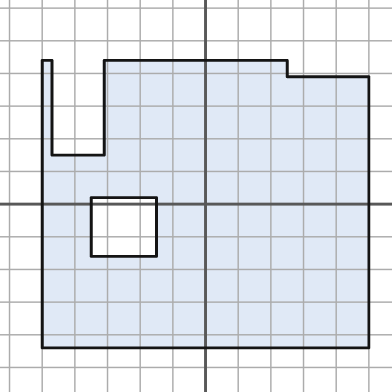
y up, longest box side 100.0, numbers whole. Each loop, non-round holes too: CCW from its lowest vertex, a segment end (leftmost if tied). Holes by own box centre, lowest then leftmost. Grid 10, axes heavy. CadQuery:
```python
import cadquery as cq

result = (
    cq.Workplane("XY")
    .moveTo(-50.0, -44.0)
    .lineTo(50.0, -44.0)
    .lineTo(50.0, 39.0)
    .lineTo(25.0, 39.0)
    .lineTo(25.0, 44.0)
    .lineTo(-31.0, 44.0)
    .lineTo(-31.0, 15.0)
    .lineTo(-47.0, 15.0)
    .lineTo(-47.0, 44.0)
    .lineTo(-50.0, 44.0)
    .close()
    .moveTo(-35.0, -16.0)
    .lineTo(-15.0, -16.0)
    .lineTo(-15.0, 2.0)
    .lineTo(-35.0, 2.0)
    .close()
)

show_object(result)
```